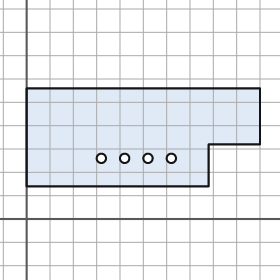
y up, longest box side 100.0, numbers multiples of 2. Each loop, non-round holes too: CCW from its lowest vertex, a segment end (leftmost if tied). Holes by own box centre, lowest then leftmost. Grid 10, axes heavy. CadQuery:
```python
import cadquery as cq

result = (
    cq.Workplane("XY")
    .moveTo(0.0, 14.0)
    .lineTo(78.0, 14.0)
    .lineTo(78.0, 32.0)
    .lineTo(100.0, 32.0)
    .lineTo(100.0, 56.0)
    .lineTo(0.0, 56.0)
    .close()
    .moveTo(32.0, 26.0)
    .circle(2.0)
    .moveTo(42.0, 26.0)
    .circle(2.0)
    .moveTo(52.0, 26.0)
    .circle(2.0)
    .moveTo(62.0, 26.0)
    .circle(2.0)
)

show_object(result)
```